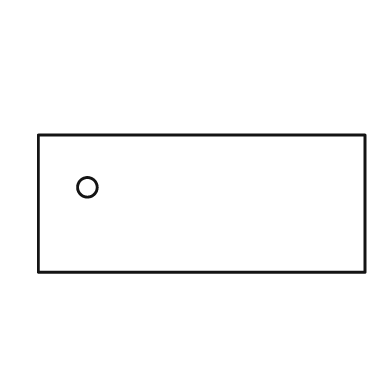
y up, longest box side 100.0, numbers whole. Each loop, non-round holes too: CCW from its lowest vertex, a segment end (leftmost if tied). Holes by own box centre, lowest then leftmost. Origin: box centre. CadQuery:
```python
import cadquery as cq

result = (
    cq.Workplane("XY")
    .moveTo(-50.0, -21.0)
    .lineTo(50.0, -21.0)
    .lineTo(50.0, 21.0)
    .lineTo(-50.0, 21.0)
    .close()
    .moveTo(-35.0, 5.0)
    .circle(3.0)
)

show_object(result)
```